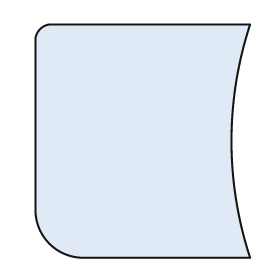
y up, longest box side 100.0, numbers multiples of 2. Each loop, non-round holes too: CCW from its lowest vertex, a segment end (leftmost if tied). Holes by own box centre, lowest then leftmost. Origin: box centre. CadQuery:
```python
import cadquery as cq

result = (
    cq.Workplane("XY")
    .moveTo(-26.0, -50.0)
    .lineTo(46.0, -50.0)
    .threePointArc((38.0, 0.0), (46.0, 50.0))
    .lineTo(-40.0, 50.0)
    .threePointArc((-44.0, 48.0), (-46.0, 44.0))
    .lineTo(-46.0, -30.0)
    .threePointArc((-40.0, -44.0), (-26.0, -50.0))
    .close()
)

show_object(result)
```